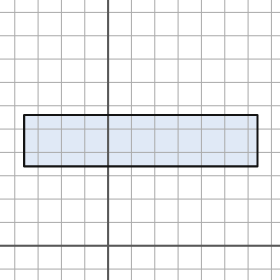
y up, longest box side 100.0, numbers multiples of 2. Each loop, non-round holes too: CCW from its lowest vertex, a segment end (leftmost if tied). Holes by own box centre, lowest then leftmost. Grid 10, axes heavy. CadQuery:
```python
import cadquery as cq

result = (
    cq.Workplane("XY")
    .moveTo(-36.0, 34.0)
    .lineTo(64.0, 34.0)
    .lineTo(64.0, 56.0)
    .lineTo(-36.0, 56.0)
    .close()
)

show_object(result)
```